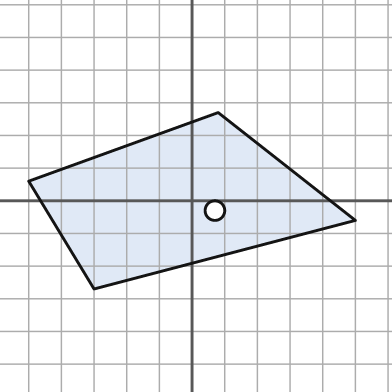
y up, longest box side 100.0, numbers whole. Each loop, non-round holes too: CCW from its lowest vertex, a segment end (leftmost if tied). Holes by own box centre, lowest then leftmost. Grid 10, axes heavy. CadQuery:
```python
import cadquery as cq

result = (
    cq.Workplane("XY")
    .moveTo(-30.0, -27.0)
    .lineTo(50.0, -6.0)
    .lineTo(8.0, 27.0)
    .lineTo(-50.0, 6.0)
    .close()
    .moveTo(7.0, -3.0)
    .circle(3.0)
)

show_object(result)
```